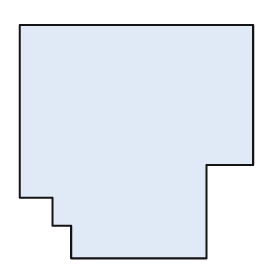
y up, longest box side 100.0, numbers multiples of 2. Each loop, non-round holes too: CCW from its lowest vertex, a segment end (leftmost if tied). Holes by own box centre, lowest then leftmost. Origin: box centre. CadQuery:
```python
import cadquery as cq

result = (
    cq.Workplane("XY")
    .moveTo(-28.0, -50.0)
    .lineTo(30.0, -50.0)
    .lineTo(30.0, -10.0)
    .lineTo(50.0, -10.0)
    .lineTo(50.0, 50.0)
    .lineTo(-50.0, 50.0)
    .lineTo(-50.0, -24.0)
    .lineTo(-36.0, -24.0)
    .lineTo(-36.0, -36.0)
    .lineTo(-28.0, -36.0)
    .close()
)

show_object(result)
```